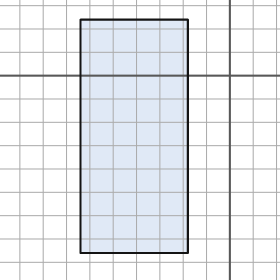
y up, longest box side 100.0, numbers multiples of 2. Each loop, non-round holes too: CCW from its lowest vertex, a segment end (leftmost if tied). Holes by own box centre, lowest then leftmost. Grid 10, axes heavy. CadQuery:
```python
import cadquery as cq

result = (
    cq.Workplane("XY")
    .moveTo(-64.0, -76.0)
    .lineTo(-18.0, -76.0)
    .lineTo(-18.0, 24.0)
    .lineTo(-64.0, 24.0)
    .close()
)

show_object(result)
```